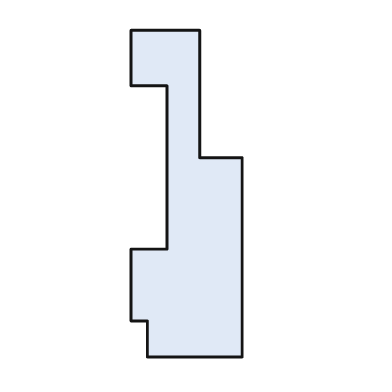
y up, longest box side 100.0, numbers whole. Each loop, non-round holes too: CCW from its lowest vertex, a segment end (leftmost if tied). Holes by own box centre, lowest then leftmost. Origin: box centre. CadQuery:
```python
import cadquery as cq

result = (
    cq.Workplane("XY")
    .moveTo(-12.0, -50.0)
    .lineTo(17.0, -50.0)
    .lineTo(17.0, 11.0)
    .lineTo(4.0, 11.0)
    .lineTo(4.0, 50.0)
    .lineTo(-17.0, 50.0)
    .lineTo(-17.0, 33.0)
    .lineTo(-6.0, 33.0)
    .lineTo(-6.0, -17.0)
    .lineTo(-17.0, -17.0)
    .lineTo(-17.0, -39.0)
    .lineTo(-12.0, -39.0)
    .close()
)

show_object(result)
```